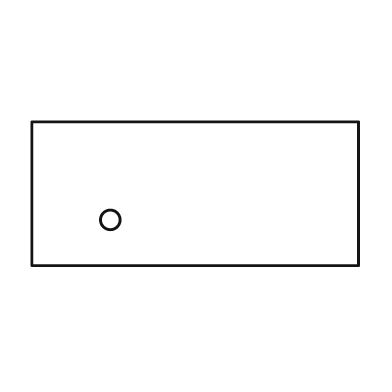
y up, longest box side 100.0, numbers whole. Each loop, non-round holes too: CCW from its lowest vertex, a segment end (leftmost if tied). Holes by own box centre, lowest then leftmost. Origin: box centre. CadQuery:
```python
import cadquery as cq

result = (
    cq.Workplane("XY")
    .moveTo(-50.0, -22.0)
    .lineTo(50.0, -22.0)
    .lineTo(50.0, 22.0)
    .lineTo(-50.0, 22.0)
    .close()
    .moveTo(-26.0, -8.0)
    .circle(3.0)
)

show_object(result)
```